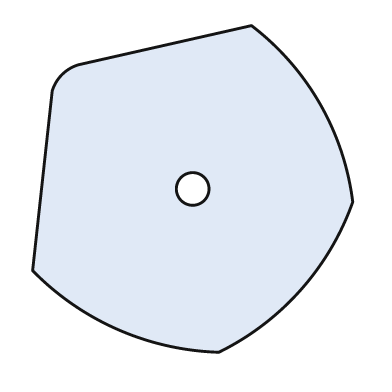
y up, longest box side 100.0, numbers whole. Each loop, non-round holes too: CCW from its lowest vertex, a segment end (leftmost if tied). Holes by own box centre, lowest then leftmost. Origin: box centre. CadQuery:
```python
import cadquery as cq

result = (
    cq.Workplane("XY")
    .moveTo(8.0, -50.0)
    .threePointArc((33.0, -31.0), (49.0, -4.0))
    .threePointArc((39.0, 26.0), (18.0, 50.0))
    .lineTo(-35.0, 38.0)
    .threePointArc((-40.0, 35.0), (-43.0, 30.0))
    .lineTo(-49.0, -25.0)
    .threePointArc((-23.0, -43.0), (8.0, -50.0))
    .close()
    .moveTo(0.0, 0.0)
    .circle(5.0)
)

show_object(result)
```